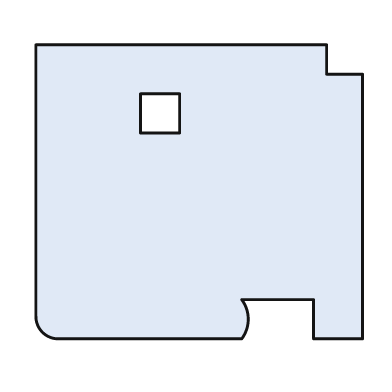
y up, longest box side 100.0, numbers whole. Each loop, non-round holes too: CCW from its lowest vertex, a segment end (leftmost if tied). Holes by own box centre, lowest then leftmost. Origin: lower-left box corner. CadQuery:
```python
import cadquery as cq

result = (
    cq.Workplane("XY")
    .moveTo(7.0, 0.0)
    .lineTo(63.0, 0.0)
    .threePointArc((65.0, 6.0), (63.0, 12.0))
    .lineTo(85.0, 12.0)
    .lineTo(85.0, 0.0)
    .lineTo(100.0, 0.0)
    .lineTo(100.0, 81.0)
    .lineTo(89.0, 81.0)
    .lineTo(89.0, 90.0)
    .lineTo(0.0, 90.0)
    .lineTo(0.0, 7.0)
    .threePointArc((2.0, 2.0), (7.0, 0.0))
    .close()
    .moveTo(32.0, 63.0)
    .lineTo(44.0, 63.0)
    .lineTo(44.0, 75.0)
    .lineTo(32.0, 75.0)
    .close()
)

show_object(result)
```